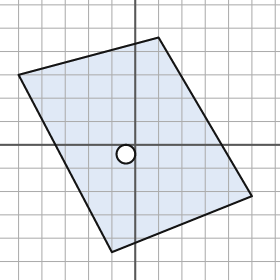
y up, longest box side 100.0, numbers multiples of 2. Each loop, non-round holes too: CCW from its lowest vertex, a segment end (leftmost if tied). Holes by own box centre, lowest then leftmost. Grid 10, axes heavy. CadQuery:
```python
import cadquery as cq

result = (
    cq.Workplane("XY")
    .moveTo(-10.0, -46.0)
    .lineTo(50.0, -22.0)
    .lineTo(10.0, 46.0)
    .lineTo(-50.0, 30.0)
    .close()
    .moveTo(-4.0, -4.0)
    .circle(4.0)
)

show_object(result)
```